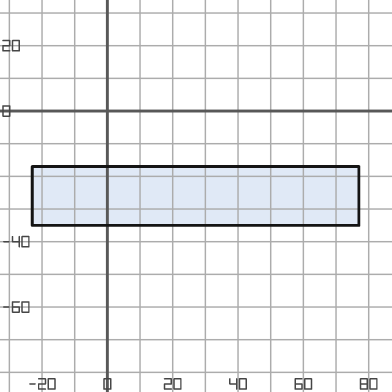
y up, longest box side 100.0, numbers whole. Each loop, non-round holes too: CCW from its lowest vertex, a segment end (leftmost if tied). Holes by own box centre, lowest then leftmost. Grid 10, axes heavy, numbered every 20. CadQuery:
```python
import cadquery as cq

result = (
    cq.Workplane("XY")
    .moveTo(-23.0, -35.0)
    .lineTo(77.0, -35.0)
    .lineTo(77.0, -17.0)
    .lineTo(-23.0, -17.0)
    .close()
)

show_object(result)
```